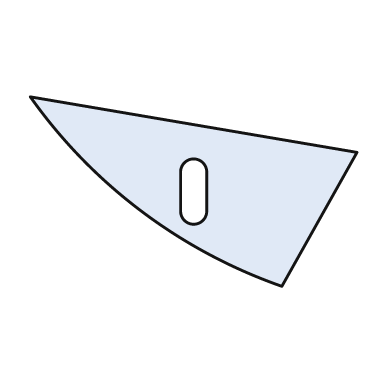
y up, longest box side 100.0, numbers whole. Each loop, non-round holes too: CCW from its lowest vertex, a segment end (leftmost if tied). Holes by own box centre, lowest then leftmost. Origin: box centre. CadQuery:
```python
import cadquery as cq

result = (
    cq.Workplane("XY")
    .moveTo(27.0, -29.0)
    .lineTo(50.0, 12.0)
    .lineTo(-50.0, 29.0)
    .threePointArc((-16.0, -6.0), (27.0, -29.0))
    .close()
    .moveTo(-4.0, -6.0)
    .threePointArc((0.0, -10.0), (4.0, -6.0))
    .lineTo(4.0, 6.0)
    .threePointArc((0.0, 10.0), (-4.0, 6.0))
    .close()
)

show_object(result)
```